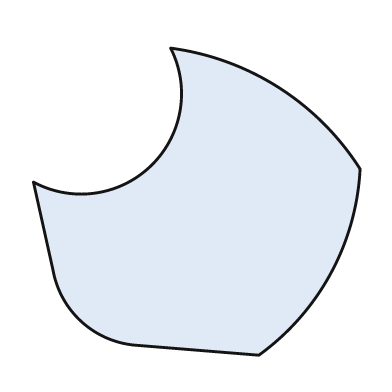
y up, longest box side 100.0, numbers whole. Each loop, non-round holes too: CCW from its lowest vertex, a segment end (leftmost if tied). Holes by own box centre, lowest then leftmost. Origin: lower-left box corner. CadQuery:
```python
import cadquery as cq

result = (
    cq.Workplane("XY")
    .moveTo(69.0, 0.0)
    .threePointArc((91.0, 25.0), (100.0, 57.0))
    .threePointArc((75.0, 82.0), (42.0, 94.0))
    .threePointArc((36.0, 58.0), (0.0, 53.0))
    .lineTo(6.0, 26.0)
    .threePointArc((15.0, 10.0), (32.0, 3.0))
    .close()
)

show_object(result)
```